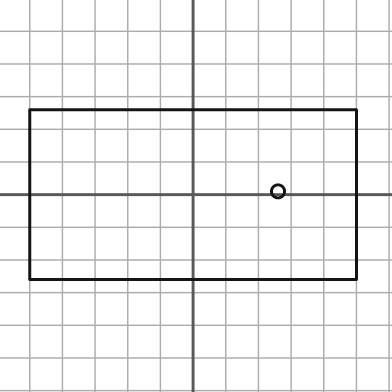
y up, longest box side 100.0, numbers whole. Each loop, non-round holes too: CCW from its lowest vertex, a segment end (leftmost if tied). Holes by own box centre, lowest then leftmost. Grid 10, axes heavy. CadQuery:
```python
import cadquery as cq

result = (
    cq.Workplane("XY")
    .moveTo(-50.0, -26.0)
    .lineTo(50.0, -26.0)
    .lineTo(50.0, 26.0)
    .lineTo(-50.0, 26.0)
    .close()
    .moveTo(26.0, 1.0)
    .circle(2.0)
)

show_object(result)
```